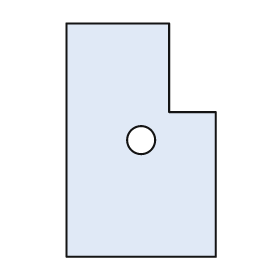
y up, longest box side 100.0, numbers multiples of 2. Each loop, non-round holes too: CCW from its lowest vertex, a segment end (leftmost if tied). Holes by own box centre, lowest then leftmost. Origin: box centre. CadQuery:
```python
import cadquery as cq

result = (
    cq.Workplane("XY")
    .moveTo(-32.0, -50.0)
    .lineTo(32.0, -50.0)
    .lineTo(32.0, 12.0)
    .lineTo(12.0, 12.0)
    .lineTo(12.0, 50.0)
    .lineTo(-32.0, 50.0)
    .close()
    .moveTo(0.0, 0.0)
    .circle(6.0)
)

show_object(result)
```